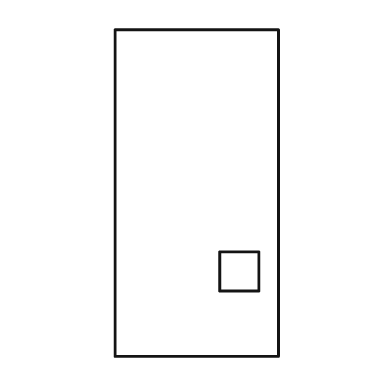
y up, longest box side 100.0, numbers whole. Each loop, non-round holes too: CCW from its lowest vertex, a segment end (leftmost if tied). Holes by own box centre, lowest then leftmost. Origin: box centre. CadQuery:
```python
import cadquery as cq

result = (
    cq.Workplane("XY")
    .moveTo(-25.0, -50.0)
    .lineTo(25.0, -50.0)
    .lineTo(25.0, 50.0)
    .lineTo(-25.0, 50.0)
    .close()
    .moveTo(7.0, -30.0)
    .lineTo(19.0, -30.0)
    .lineTo(19.0, -18.0)
    .lineTo(7.0, -18.0)
    .close()
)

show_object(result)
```